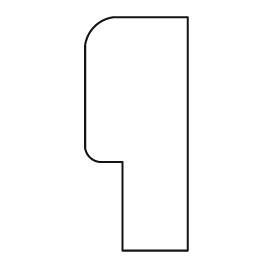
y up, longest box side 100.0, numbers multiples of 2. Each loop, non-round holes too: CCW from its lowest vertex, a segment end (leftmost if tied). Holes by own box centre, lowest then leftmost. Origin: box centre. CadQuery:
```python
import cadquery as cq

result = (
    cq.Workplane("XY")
    .moveTo(-6.0, -50.0)
    .lineTo(22.0, -50.0)
    .lineTo(22.0, 50.0)
    .lineTo(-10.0, 50.0)
    .threePointArc((-18.0, 46.0), (-22.0, 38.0))
    .lineTo(-22.0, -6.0)
    .threePointArc((-20.0, -10.0), (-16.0, -12.0))
    .lineTo(-6.0, -12.0)
    .close()
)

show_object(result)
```